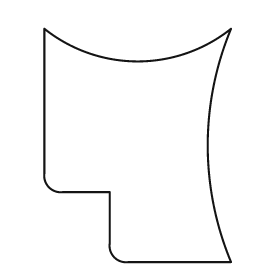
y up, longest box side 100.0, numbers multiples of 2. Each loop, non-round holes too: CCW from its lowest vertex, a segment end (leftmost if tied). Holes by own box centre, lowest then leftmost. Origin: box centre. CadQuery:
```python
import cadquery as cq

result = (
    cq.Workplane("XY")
    .moveTo(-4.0, -50.0)
    .lineTo(40.0, -50.0)
    .threePointArc((30.0, 0.0), (40.0, 50.0))
    .threePointArc((0.0, 36.0), (-40.0, 50.0))
    .lineTo(-40.0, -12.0)
    .threePointArc((-38.0, -18.0), (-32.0, -20.0))
    .lineTo(-12.0, -20.0)
    .lineTo(-12.0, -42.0)
    .threePointArc((-10.0, -48.0), (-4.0, -50.0))
    .close()
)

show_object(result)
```